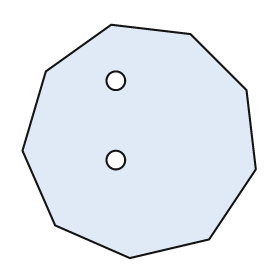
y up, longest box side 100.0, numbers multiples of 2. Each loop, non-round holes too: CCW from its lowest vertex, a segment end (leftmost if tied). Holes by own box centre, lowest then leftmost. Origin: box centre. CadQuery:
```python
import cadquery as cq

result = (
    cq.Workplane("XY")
    .moveTo(-4.0, -50.0)
    .lineTo(30.0, -42.0)
    .lineTo(50.0, -12.0)
    .lineTo(46.0, 22.0)
    .lineTo(22.0, 46.0)
    .lineTo(-12.0, 50.0)
    .lineTo(-40.0, 30.0)
    .lineTo(-50.0, -4.0)
    .lineTo(-36.0, -36.0)
    .close()
    .moveTo(-10.0, -8.0)
    .circle(4.0)
    .moveTo(-10.0, 26.0)
    .circle(4.0)
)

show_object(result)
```